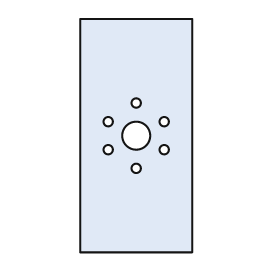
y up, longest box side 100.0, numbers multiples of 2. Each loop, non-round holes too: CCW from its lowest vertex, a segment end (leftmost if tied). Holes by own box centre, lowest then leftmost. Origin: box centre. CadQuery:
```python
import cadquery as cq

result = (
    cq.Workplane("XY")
    .moveTo(-24.0, -50.0)
    .lineTo(24.0, -50.0)
    .lineTo(24.0, 50.0)
    .lineTo(-24.0, 50.0)
    .close()
    .moveTo(0.0, -14.0)
    .circle(2.0)
    .moveTo(-12.0, -6.0)
    .circle(2.0)
    .moveTo(12.0, -6.0)
    .circle(2.0)
    .moveTo(0.0, 0.0)
    .circle(6.0)
    .moveTo(-12.0, 6.0)
    .circle(2.0)
    .moveTo(12.0, 6.0)
    .circle(2.0)
    .moveTo(0.0, 14.0)
    .circle(2.0)
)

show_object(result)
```